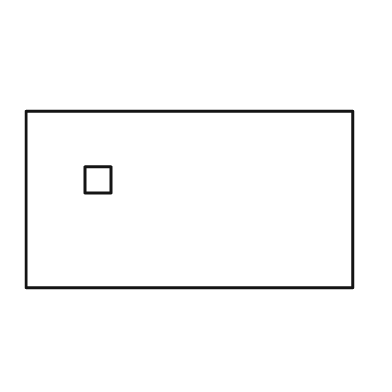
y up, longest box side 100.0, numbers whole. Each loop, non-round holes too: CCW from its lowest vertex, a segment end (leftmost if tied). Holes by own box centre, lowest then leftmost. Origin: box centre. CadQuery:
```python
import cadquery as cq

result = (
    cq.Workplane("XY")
    .moveTo(-50.0, -27.0)
    .lineTo(50.0, -27.0)
    .lineTo(50.0, 27.0)
    .lineTo(-50.0, 27.0)
    .close()
    .moveTo(-32.0, 2.0)
    .lineTo(-24.0, 2.0)
    .lineTo(-24.0, 10.0)
    .lineTo(-32.0, 10.0)
    .close()
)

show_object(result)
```